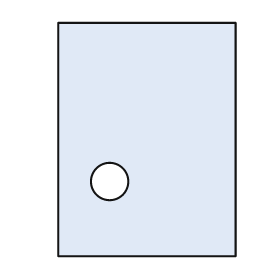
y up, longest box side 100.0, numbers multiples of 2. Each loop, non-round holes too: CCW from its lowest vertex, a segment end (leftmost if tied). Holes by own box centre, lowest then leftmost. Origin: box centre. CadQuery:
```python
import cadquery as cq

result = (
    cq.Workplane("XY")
    .moveTo(-38.0, -50.0)
    .lineTo(38.0, -50.0)
    .lineTo(38.0, 50.0)
    .lineTo(-38.0, 50.0)
    .close()
    .moveTo(-16.0, -18.0)
    .circle(8.0)
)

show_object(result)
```